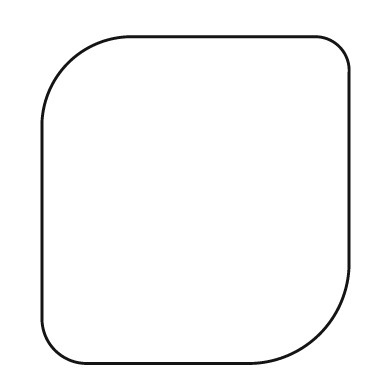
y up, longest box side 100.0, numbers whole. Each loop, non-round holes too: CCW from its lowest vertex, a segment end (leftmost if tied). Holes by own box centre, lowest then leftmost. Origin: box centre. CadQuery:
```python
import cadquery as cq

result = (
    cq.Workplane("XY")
    .moveTo(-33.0, -50.0)
    .lineTo(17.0, -50.0)
    .threePointArc((38.0, -41.0), (47.0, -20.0))
    .lineTo(47.0, 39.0)
    .threePointArc((44.0, 47.0), (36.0, 50.0))
    .lineTo(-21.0, 50.0)
    .threePointArc((-39.0, 42.0), (-47.0, 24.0))
    .lineTo(-47.0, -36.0)
    .threePointArc((-43.0, -46.0), (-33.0, -50.0))
    .close()
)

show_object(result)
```